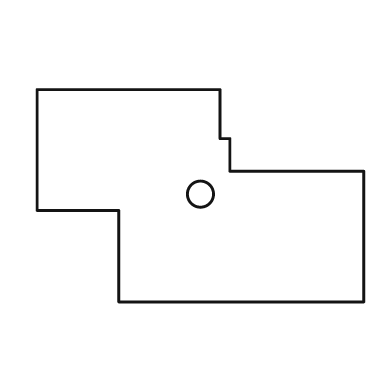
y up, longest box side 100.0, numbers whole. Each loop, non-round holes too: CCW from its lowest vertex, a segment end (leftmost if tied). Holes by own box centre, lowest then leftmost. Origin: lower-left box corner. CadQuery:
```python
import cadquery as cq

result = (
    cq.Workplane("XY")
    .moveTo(25.0, 0.0)
    .lineTo(100.0, 0.0)
    .lineTo(100.0, 40.0)
    .lineTo(59.0, 40.0)
    .lineTo(59.0, 50.0)
    .lineTo(56.0, 50.0)
    .lineTo(56.0, 65.0)
    .lineTo(0.0, 65.0)
    .lineTo(0.0, 28.0)
    .lineTo(25.0, 28.0)
    .close()
    .moveTo(50.0, 33.0)
    .circle(4.0)
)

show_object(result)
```